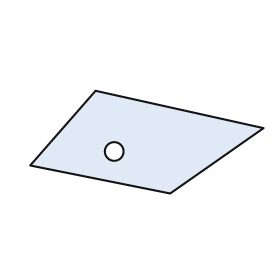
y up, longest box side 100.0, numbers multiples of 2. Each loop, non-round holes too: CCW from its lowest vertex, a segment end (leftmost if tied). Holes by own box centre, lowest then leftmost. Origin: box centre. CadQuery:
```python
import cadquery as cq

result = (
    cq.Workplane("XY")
    .moveTo(10.0, -22.0)
    .lineTo(50.0, 6.0)
    .lineTo(-22.0, 22.0)
    .lineTo(-50.0, -10.0)
    .close()
    .moveTo(-14.0, -4.0)
    .circle(4.0)
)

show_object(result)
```